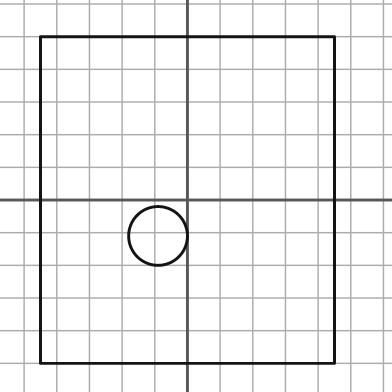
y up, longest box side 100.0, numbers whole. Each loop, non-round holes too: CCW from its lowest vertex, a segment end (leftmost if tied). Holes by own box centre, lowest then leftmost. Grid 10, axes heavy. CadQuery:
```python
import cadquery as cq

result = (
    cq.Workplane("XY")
    .moveTo(-45.0, -50.0)
    .lineTo(45.0, -50.0)
    .lineTo(45.0, 50.0)
    .lineTo(-45.0, 50.0)
    .close()
    .moveTo(-9.0, -11.0)
    .circle(9.0)
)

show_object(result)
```